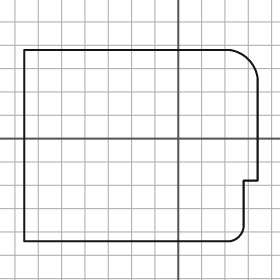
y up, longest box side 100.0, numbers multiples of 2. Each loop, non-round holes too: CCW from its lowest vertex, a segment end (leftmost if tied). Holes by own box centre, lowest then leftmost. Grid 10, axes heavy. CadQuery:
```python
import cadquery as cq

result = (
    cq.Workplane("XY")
    .moveTo(-66.0, -44.0)
    .lineTo(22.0, -44.0)
    .threePointArc((26.0, -42.0), (28.0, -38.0))
    .lineTo(28.0, -18.0)
    .lineTo(34.0, -18.0)
    .lineTo(34.0, 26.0)
    .threePointArc((30.0, 34.0), (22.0, 38.0))
    .lineTo(-66.0, 38.0)
    .close()
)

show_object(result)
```